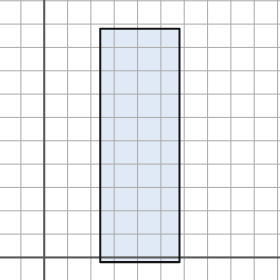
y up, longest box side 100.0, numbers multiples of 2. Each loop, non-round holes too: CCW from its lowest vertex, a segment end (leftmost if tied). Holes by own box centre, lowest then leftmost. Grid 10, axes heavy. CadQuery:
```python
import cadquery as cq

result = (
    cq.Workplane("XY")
    .moveTo(24.0, -2.0)
    .lineTo(58.0, -2.0)
    .lineTo(58.0, 98.0)
    .lineTo(24.0, 98.0)
    .close()
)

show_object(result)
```